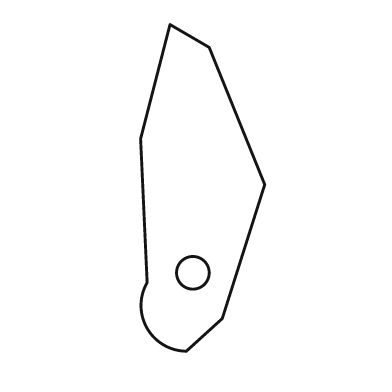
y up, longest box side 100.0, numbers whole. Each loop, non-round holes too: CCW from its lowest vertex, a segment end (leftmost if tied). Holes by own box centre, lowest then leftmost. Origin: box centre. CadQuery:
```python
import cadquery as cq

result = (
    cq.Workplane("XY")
    .moveTo(-5.0, -50.0)
    .lineTo(6.0, -40.0)
    .lineTo(19.0, 1.0)
    .lineTo(2.0, 43.0)
    .lineTo(-10.0, 50.0)
    .lineTo(-19.0, 15.0)
    .lineTo(-17.0, -29.0)
    .threePointArc((-17.0, -43.0), (-5.0, -50.0))
    .close()
    .moveTo(-3.0, -26.0)
    .circle(5.0)
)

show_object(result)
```